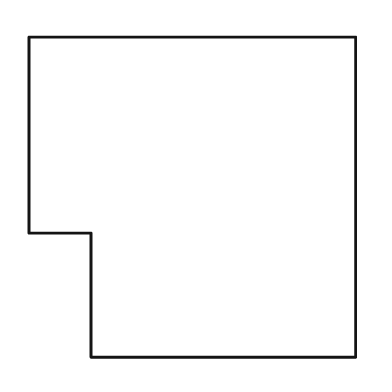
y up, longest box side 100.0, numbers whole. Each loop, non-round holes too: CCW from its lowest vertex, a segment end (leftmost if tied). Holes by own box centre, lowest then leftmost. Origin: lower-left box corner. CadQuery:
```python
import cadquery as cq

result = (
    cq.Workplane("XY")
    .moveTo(19.0, 0.0)
    .lineTo(100.0, 0.0)
    .lineTo(100.0, 98.0)
    .lineTo(0.0, 98.0)
    .lineTo(0.0, 38.0)
    .lineTo(19.0, 38.0)
    .close()
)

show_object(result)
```